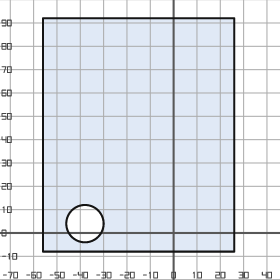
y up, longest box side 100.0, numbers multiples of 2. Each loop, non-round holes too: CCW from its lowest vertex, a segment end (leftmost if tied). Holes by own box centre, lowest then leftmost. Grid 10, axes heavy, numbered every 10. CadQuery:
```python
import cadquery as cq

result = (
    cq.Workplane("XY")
    .moveTo(-56.0, -8.0)
    .lineTo(26.0, -8.0)
    .lineTo(26.0, 92.0)
    .lineTo(-56.0, 92.0)
    .close()
    .moveTo(-38.0, 4.0)
    .circle(8.0)
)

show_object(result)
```